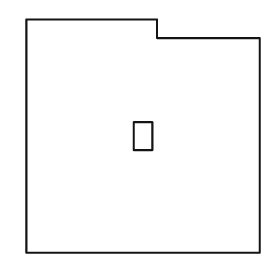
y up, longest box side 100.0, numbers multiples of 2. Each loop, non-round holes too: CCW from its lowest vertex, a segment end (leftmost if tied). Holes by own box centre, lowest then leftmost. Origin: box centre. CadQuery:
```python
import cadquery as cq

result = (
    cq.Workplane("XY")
    .moveTo(-50.0, -50.0)
    .lineTo(50.0, -50.0)
    .lineTo(50.0, 42.0)
    .lineTo(6.0, 42.0)
    .lineTo(6.0, 50.0)
    .lineTo(-50.0, 50.0)
    .close()
    .moveTo(-4.0, -6.0)
    .lineTo(4.0, -6.0)
    .lineTo(4.0, 6.0)
    .lineTo(-4.0, 6.0)
    .close()
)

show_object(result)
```